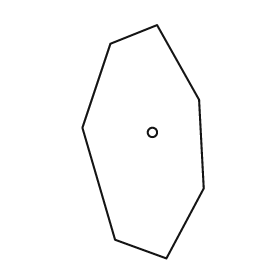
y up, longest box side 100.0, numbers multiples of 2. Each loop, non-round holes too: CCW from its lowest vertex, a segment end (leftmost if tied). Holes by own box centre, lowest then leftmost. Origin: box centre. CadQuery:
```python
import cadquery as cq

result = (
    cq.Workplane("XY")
    .moveTo(10.0, -50.0)
    .lineTo(26.0, -20.0)
    .lineTo(24.0, 18.0)
    .lineTo(6.0, 50.0)
    .lineTo(-14.0, 42.0)
    .lineTo(-26.0, 6.0)
    .lineTo(-12.0, -42.0)
    .close()
    .moveTo(4.0, 4.0)
    .circle(2.0)
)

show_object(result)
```